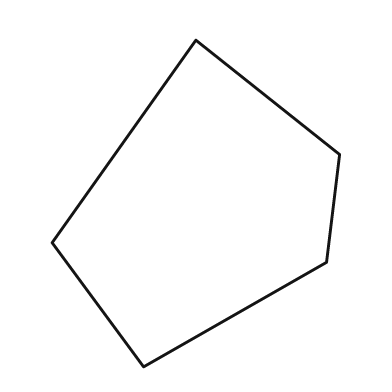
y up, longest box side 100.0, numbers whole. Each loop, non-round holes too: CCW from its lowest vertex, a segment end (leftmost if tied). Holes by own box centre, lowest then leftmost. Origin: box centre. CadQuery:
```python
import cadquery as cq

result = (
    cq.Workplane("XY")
    .moveTo(-16.0, -50.0)
    .lineTo(40.0, -18.0)
    .lineTo(44.0, 15.0)
    .lineTo(0.0, 50.0)
    .lineTo(-44.0, -12.0)
    .close()
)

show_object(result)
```